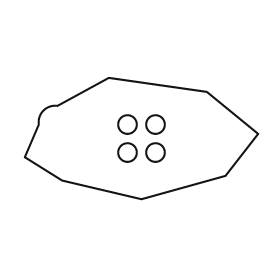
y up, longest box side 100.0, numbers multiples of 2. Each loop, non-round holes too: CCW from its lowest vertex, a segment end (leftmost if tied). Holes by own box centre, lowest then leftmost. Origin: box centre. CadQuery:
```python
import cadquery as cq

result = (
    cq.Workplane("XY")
    .moveTo(0.0, -26.0)
    .lineTo(36.0, -16.0)
    .lineTo(50.0, 2.0)
    .lineTo(28.0, 20.0)
    .lineTo(-14.0, 26.0)
    .lineTo(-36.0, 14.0)
    .threePointArc((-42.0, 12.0), (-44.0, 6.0))
    .lineTo(-50.0, -8.0)
    .lineTo(-34.0, -18.0)
    .close()
    .moveTo(-6.0, -6.0)
    .circle(4.0)
    .moveTo(6.0, -6.0)
    .circle(4.0)
    .moveTo(-6.0, 6.0)
    .circle(4.0)
    .moveTo(6.0, 6.0)
    .circle(4.0)
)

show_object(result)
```